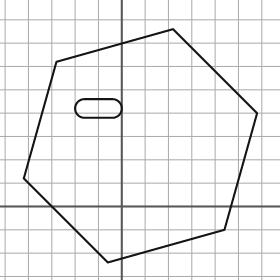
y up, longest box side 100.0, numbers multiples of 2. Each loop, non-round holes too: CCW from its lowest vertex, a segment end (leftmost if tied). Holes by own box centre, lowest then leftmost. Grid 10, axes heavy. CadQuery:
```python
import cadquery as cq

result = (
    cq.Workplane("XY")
    .moveTo(-6.0, -24.0)
    .lineTo(44.0, -10.0)
    .lineTo(58.0, 40.0)
    .lineTo(22.0, 76.0)
    .lineTo(-28.0, 62.0)
    .lineTo(-42.0, 12.0)
    .close()
    .moveTo(-16.0, 38.0)
    .lineTo(-4.0, 38.0)
    .threePointArc((0.0, 42.0), (-4.0, 46.0))
    .lineTo(-16.0, 46.0)
    .threePointArc((-20.0, 42.0), (-16.0, 38.0))
    .close()
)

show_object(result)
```